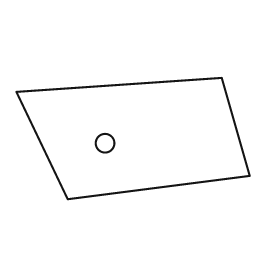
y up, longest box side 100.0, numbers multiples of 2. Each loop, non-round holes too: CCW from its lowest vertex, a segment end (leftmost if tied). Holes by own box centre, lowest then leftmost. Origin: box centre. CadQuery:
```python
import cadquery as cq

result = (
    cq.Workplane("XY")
    .moveTo(-28.0, -26.0)
    .lineTo(50.0, -16.0)
    .lineTo(38.0, 26.0)
    .lineTo(-50.0, 20.0)
    .close()
    .moveTo(-12.0, -2.0)
    .circle(4.0)
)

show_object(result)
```